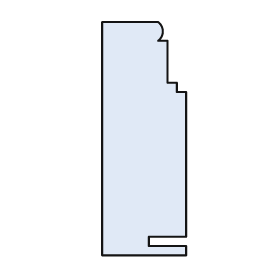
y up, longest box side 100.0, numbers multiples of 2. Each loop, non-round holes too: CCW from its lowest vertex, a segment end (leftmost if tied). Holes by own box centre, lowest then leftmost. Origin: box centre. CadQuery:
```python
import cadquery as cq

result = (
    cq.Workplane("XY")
    .moveTo(-18.0, -50.0)
    .lineTo(18.0, -50.0)
    .lineTo(18.0, -46.0)
    .lineTo(2.0, -46.0)
    .lineTo(2.0, -42.0)
    .lineTo(18.0, -42.0)
    .lineTo(18.0, 20.0)
    .lineTo(14.0, 20.0)
    .lineTo(14.0, 24.0)
    .lineTo(10.0, 24.0)
    .lineTo(10.0, 42.0)
    .lineTo(6.0, 42.0)
    .threePointArc((8.0, 46.0), (6.0, 50.0))
    .lineTo(-18.0, 50.0)
    .close()
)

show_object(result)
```